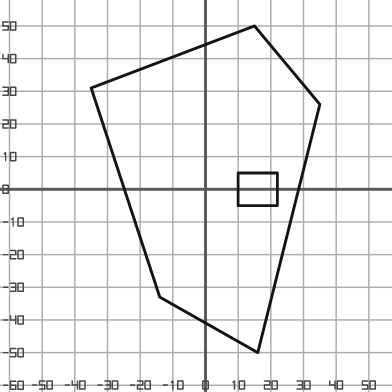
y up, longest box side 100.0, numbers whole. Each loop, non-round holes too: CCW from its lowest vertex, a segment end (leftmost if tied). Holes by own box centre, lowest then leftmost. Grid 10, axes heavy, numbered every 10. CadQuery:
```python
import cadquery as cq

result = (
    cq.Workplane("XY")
    .moveTo(16.0, -50.0)
    .lineTo(35.0, 26.0)
    .lineTo(15.0, 50.0)
    .lineTo(-35.0, 31.0)
    .lineTo(-14.0, -33.0)
    .close()
    .moveTo(10.0, -5.0)
    .lineTo(22.0, -5.0)
    .lineTo(22.0, 5.0)
    .lineTo(10.0, 5.0)
    .close()
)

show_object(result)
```